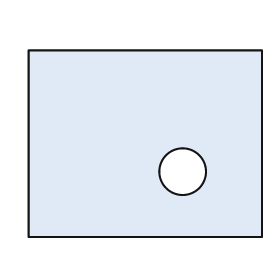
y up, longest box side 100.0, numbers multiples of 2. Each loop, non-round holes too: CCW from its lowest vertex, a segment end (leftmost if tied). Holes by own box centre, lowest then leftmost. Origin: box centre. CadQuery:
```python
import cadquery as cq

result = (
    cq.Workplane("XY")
    .moveTo(-50.0, -40.0)
    .lineTo(50.0, -40.0)
    .lineTo(50.0, 40.0)
    .lineTo(-50.0, 40.0)
    .close()
    .moveTo(16.0, -12.0)
    .circle(10.0)
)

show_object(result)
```